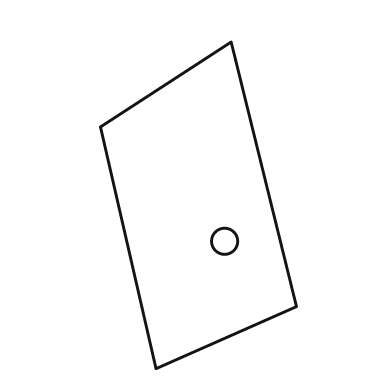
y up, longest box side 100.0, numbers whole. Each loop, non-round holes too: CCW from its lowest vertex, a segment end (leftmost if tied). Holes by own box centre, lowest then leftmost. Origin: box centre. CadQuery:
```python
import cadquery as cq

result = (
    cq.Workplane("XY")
    .moveTo(-13.0, -50.0)
    .lineTo(30.0, -31.0)
    .lineTo(10.0, 50.0)
    .lineTo(-30.0, 24.0)
    .close()
    .moveTo(8.0, -11.0)
    .circle(4.0)
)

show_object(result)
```